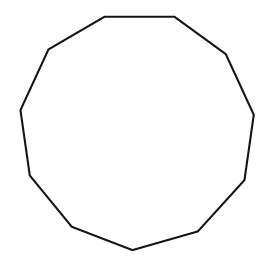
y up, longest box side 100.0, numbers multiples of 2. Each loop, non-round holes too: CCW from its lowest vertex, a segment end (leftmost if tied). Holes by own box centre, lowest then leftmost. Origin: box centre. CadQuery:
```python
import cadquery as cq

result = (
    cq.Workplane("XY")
    .moveTo(-2.0, -50.0)
    .lineTo(26.0, -42.0)
    .lineTo(46.0, -20.0)
    .lineTo(50.0, 8.0)
    .lineTo(38.0, 34.0)
    .lineTo(16.0, 50.0)
    .lineTo(-14.0, 50.0)
    .lineTo(-38.0, 36.0)
    .lineTo(-50.0, 10.0)
    .lineTo(-46.0, -18.0)
    .lineTo(-28.0, -40.0)
    .close()
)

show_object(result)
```